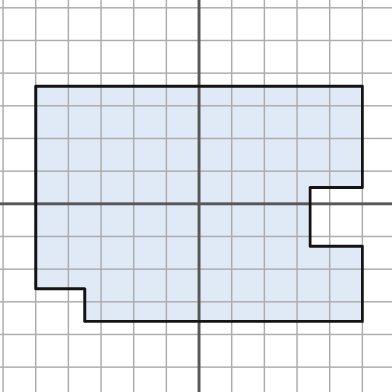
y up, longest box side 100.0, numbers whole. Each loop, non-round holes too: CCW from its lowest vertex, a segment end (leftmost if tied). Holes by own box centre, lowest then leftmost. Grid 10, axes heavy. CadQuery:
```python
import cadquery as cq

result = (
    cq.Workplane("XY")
    .moveTo(-35.0, -36.0)
    .lineTo(50.0, -36.0)
    .lineTo(50.0, -13.0)
    .lineTo(34.0, -13.0)
    .lineTo(34.0, 5.0)
    .lineTo(50.0, 5.0)
    .lineTo(50.0, 36.0)
    .lineTo(-50.0, 36.0)
    .lineTo(-50.0, -26.0)
    .lineTo(-35.0, -26.0)
    .close()
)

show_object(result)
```